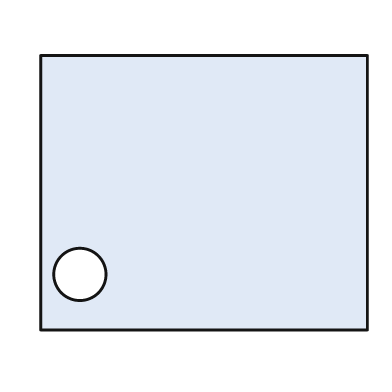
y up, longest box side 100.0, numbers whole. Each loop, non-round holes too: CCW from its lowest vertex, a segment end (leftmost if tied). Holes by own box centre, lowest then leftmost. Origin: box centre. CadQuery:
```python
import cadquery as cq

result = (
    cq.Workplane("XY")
    .moveTo(-50.0, -42.0)
    .lineTo(50.0, -42.0)
    .lineTo(50.0, 42.0)
    .lineTo(-50.0, 42.0)
    .close()
    .moveTo(-38.0, -25.0)
    .circle(8.0)
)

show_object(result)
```